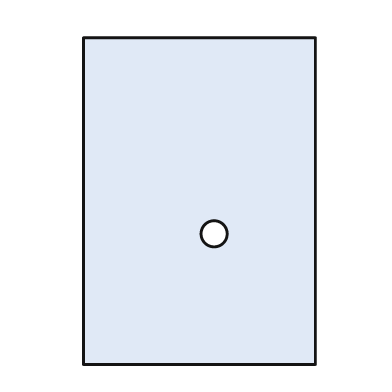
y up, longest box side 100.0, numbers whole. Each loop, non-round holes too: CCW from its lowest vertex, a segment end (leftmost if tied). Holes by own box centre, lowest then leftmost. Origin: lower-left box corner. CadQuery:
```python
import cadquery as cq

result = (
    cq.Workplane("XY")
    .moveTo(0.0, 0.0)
    .lineTo(71.0, 0.0)
    .lineTo(71.0, 100.0)
    .lineTo(0.0, 100.0)
    .close()
    .moveTo(40.0, 40.0)
    .circle(4.0)
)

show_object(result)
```